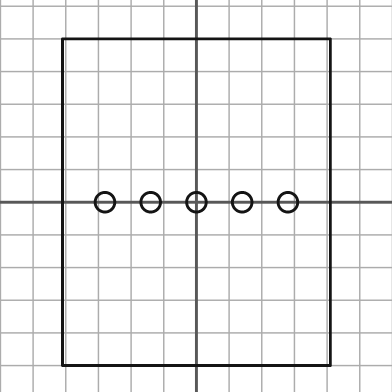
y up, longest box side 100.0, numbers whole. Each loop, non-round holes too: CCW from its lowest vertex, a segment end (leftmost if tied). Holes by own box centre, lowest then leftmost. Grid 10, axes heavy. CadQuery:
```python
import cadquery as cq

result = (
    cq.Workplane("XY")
    .moveTo(-41.0, -50.0)
    .lineTo(41.0, -50.0)
    .lineTo(41.0, 50.0)
    .lineTo(-41.0, 50.0)
    .close()
    .moveTo(-28.0, 0.0)
    .circle(3.0)
    .moveTo(-14.0, 0.0)
    .circle(3.0)
    .moveTo(0.0, 0.0)
    .circle(3.0)
    .moveTo(14.0, 0.0)
    .circle(3.0)
    .moveTo(28.0, 0.0)
    .circle(3.0)
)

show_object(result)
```